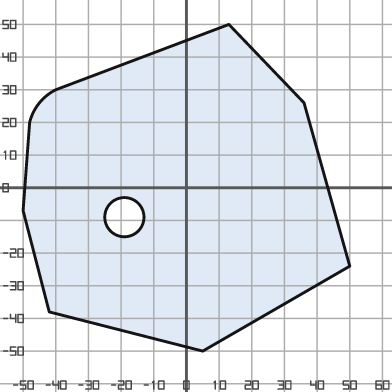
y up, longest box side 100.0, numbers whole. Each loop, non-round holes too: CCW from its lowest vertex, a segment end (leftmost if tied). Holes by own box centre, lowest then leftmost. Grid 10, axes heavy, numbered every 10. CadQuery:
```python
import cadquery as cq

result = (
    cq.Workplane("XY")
    .moveTo(5.0, -50.0)
    .lineTo(50.0, -24.0)
    .lineTo(36.0, 26.0)
    .lineTo(13.0, 50.0)
    .lineTo(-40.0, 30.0)
    .threePointArc((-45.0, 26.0), (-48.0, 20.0))
    .lineTo(-50.0, -7.0)
    .lineTo(-42.0, -38.0)
    .close()
    .moveTo(-19.0, -9.0)
    .circle(6.0)
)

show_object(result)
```